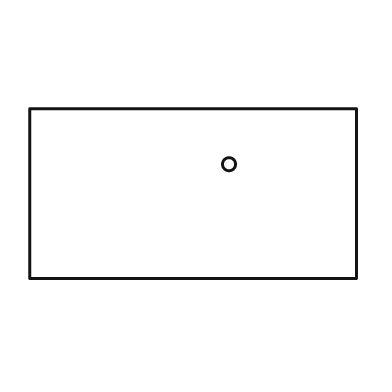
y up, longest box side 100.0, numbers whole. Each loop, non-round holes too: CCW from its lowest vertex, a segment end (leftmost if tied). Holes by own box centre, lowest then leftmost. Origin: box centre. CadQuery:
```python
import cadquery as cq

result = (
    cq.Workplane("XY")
    .moveTo(-50.0, -26.0)
    .lineTo(50.0, -26.0)
    .lineTo(50.0, 26.0)
    .lineTo(-50.0, 26.0)
    .close()
    .moveTo(11.0, 9.0)
    .circle(2.0)
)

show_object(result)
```